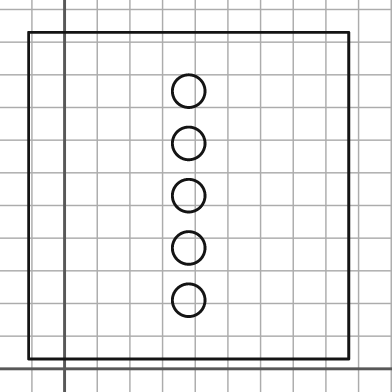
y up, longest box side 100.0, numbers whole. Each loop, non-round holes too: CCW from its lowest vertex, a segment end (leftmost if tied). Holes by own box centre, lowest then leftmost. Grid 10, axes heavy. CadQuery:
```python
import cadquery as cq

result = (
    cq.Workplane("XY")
    .moveTo(-11.0, 3.0)
    .lineTo(87.0, 3.0)
    .lineTo(87.0, 103.0)
    .lineTo(-11.0, 103.0)
    .close()
    .moveTo(38.0, 21.0)
    .circle(5.0)
    .moveTo(38.0, 37.0)
    .circle(5.0)
    .moveTo(38.0, 53.0)
    .circle(5.0)
    .moveTo(38.0, 69.0)
    .circle(5.0)
    .moveTo(38.0, 85.0)
    .circle(5.0)
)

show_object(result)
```